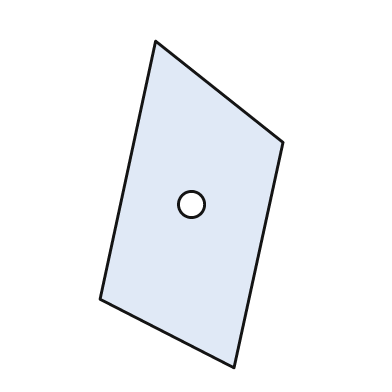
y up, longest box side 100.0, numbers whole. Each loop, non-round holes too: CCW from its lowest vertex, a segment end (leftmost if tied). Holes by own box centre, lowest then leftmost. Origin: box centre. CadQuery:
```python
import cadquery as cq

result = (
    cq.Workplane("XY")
    .moveTo(13.0, -50.0)
    .lineTo(28.0, 19.0)
    .lineTo(-11.0, 50.0)
    .lineTo(-28.0, -29.0)
    .close()
    .moveTo(0.0, 0.0)
    .circle(4.0)
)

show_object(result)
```